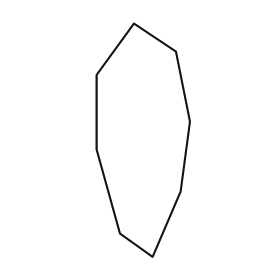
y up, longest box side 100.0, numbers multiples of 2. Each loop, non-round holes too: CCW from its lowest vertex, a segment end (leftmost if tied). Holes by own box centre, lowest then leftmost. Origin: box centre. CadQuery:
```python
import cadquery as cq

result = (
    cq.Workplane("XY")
    .moveTo(4.0, -50.0)
    .lineTo(16.0, -22.0)
    .lineTo(20.0, 8.0)
    .lineTo(14.0, 38.0)
    .lineTo(-4.0, 50.0)
    .lineTo(-20.0, 28.0)
    .lineTo(-20.0, -4.0)
    .lineTo(-10.0, -40.0)
    .close()
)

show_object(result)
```